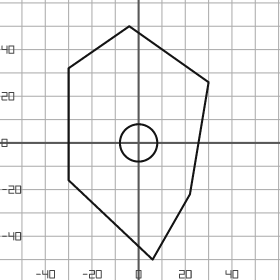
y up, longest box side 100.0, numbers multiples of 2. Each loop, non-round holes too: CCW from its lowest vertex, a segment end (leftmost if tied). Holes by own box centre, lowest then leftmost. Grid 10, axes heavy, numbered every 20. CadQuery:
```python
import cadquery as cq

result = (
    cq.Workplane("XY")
    .moveTo(6.0, -50.0)
    .lineTo(22.0, -22.0)
    .lineTo(30.0, 26.0)
    .lineTo(-4.0, 50.0)
    .lineTo(-30.0, 32.0)
    .lineTo(-30.0, -16.0)
    .close()
    .moveTo(0.0, 0.0)
    .circle(8.0)
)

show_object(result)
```